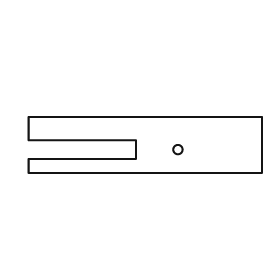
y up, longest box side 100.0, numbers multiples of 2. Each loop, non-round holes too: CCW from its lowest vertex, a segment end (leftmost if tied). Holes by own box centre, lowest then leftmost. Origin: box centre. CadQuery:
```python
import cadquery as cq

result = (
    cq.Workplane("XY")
    .moveTo(-50.0, -12.0)
    .lineTo(50.0, -12.0)
    .lineTo(50.0, 12.0)
    .lineTo(-50.0, 12.0)
    .lineTo(-50.0, 2.0)
    .lineTo(-4.0, 2.0)
    .lineTo(-4.0, -6.0)
    .lineTo(-50.0, -6.0)
    .close()
    .moveTo(14.0, -2.0)
    .circle(2.0)
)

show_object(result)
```